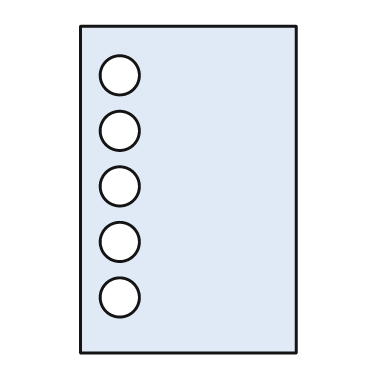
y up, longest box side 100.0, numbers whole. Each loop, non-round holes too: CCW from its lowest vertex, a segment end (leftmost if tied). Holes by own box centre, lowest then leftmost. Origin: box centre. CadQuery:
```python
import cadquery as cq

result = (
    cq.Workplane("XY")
    .moveTo(-33.0, -50.0)
    .lineTo(33.0, -50.0)
    .lineTo(33.0, 50.0)
    .lineTo(-33.0, 50.0)
    .close()
    .moveTo(-21.0, -33.0)
    .circle(6.0)
    .moveTo(-21.0, -16.0)
    .circle(6.0)
    .moveTo(-21.0, 1.0)
    .circle(6.0)
    .moveTo(-21.0, 18.0)
    .circle(6.0)
    .moveTo(-21.0, 35.0)
    .circle(6.0)
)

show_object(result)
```